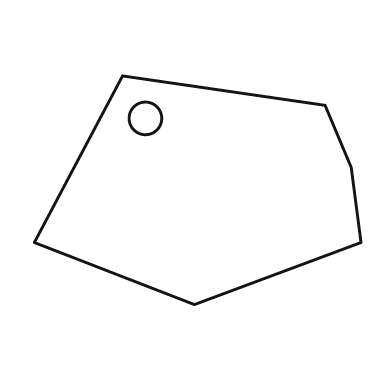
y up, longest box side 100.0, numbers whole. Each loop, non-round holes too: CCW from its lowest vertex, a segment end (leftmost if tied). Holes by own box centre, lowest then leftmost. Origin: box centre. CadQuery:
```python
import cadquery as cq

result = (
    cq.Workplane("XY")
    .moveTo(-1.0, -35.0)
    .lineTo(50.0, -16.0)
    .lineTo(47.0, 7.0)
    .lineTo(39.0, 26.0)
    .lineTo(-23.0, 35.0)
    .lineTo(-50.0, -16.0)
    .close()
    .moveTo(-16.0, 22.0)
    .circle(5.0)
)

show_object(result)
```